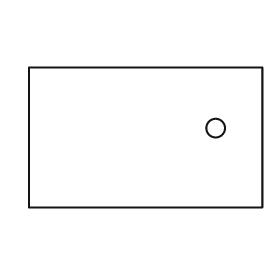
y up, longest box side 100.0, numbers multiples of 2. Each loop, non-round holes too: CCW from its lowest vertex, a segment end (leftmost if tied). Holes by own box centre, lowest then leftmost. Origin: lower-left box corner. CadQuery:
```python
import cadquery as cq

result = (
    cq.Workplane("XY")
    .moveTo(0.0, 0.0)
    .lineTo(100.0, 0.0)
    .lineTo(100.0, 60.0)
    .lineTo(0.0, 60.0)
    .close()
    .moveTo(80.0, 34.0)
    .circle(4.0)
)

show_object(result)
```